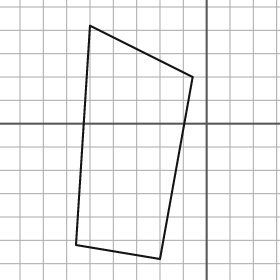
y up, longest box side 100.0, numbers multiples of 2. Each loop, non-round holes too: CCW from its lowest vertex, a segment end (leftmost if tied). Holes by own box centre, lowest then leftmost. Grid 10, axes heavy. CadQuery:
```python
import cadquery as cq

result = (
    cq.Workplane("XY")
    .moveTo(-20.0, -58.0)
    .lineTo(-6.0, 20.0)
    .lineTo(-50.0, 42.0)
    .lineTo(-56.0, -52.0)
    .close()
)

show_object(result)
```